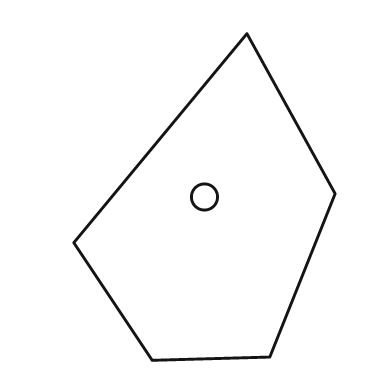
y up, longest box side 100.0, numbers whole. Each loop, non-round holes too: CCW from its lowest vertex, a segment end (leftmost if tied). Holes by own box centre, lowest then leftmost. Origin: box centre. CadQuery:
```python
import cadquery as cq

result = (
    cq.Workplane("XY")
    .moveTo(-16.0, -50.0)
    .lineTo(20.0, -49.0)
    .lineTo(40.0, 1.0)
    .lineTo(13.0, 50.0)
    .lineTo(-40.0, -14.0)
    .close()
    .moveTo(0.0, 0.0)
    .circle(4.0)
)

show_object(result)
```